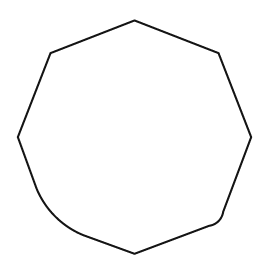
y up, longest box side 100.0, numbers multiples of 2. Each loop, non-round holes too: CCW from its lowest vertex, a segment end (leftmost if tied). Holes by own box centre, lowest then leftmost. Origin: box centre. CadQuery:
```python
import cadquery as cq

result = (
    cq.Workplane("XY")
    .moveTo(0.0, -50.0)
    .lineTo(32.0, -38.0)
    .threePointArc((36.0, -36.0), (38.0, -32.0))
    .lineTo(50.0, 0.0)
    .lineTo(36.0, 36.0)
    .lineTo(0.0, 50.0)
    .lineTo(-36.0, 36.0)
    .lineTo(-50.0, 0.0)
    .lineTo(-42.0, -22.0)
    .threePointArc((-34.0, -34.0), (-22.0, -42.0))
    .close()
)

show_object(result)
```